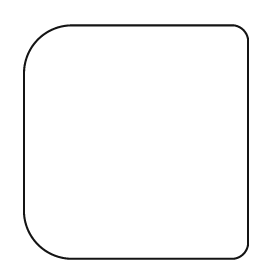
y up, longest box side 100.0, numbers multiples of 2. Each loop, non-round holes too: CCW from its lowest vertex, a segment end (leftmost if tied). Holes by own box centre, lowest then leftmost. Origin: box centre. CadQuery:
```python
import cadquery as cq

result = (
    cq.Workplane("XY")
    .moveTo(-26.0, -50.0)
    .lineTo(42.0, -50.0)
    .threePointArc((46.0, -48.0), (48.0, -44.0))
    .lineTo(48.0, 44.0)
    .threePointArc((46.0, 48.0), (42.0, 50.0))
    .lineTo(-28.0, 50.0)
    .threePointArc((-42.0, 44.0), (-48.0, 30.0))
    .lineTo(-48.0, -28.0)
    .threePointArc((-42.0, -44.0), (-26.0, -50.0))
    .close()
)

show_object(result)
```